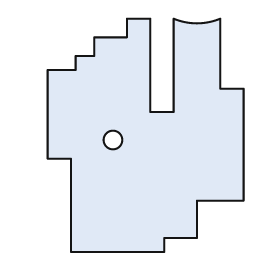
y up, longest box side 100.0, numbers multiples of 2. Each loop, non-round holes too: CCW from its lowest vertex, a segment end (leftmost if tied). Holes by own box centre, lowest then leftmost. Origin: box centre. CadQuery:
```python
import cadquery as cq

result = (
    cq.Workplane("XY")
    .moveTo(-32.0, -50.0)
    .lineTo(8.0, -50.0)
    .lineTo(8.0, -44.0)
    .lineTo(22.0, -44.0)
    .lineTo(22.0, -28.0)
    .lineTo(42.0, -28.0)
    .lineTo(42.0, 20.0)
    .lineTo(32.0, 20.0)
    .lineTo(32.0, 50.0)
    .threePointArc((22.0, 48.0), (12.0, 50.0))
    .lineTo(12.0, 10.0)
    .lineTo(2.0, 10.0)
    .lineTo(2.0, 50.0)
    .lineTo(-8.0, 50.0)
    .lineTo(-8.0, 42.0)
    .lineTo(-22.0, 42.0)
    .lineTo(-22.0, 34.0)
    .lineTo(-30.0, 34.0)
    .lineTo(-30.0, 28.0)
    .lineTo(-42.0, 28.0)
    .lineTo(-42.0, -10.0)
    .lineTo(-32.0, -10.0)
    .close()
    .moveTo(-14.0, -2.0)
    .circle(4.0)
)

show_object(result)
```